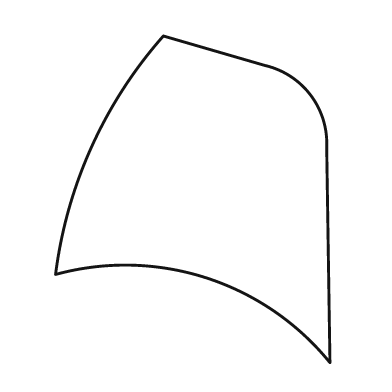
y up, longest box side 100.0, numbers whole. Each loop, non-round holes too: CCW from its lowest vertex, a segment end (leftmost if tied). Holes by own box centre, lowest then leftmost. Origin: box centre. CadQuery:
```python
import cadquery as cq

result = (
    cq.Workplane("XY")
    .moveTo(42.0, -50.0)
    .lineTo(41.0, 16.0)
    .threePointArc((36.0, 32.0), (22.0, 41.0))
    .lineTo(-9.0, 50.0)
    .threePointArc((-31.0, 16.0), (-42.0, -23.0))
    .threePointArc((4.0, -24.0), (42.0, -50.0))
    .close()
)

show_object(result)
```